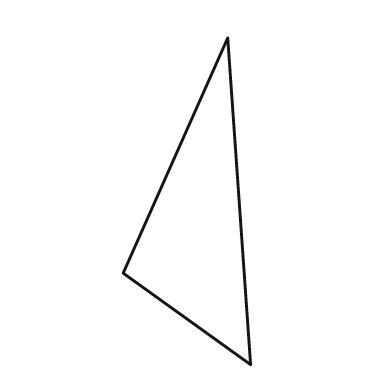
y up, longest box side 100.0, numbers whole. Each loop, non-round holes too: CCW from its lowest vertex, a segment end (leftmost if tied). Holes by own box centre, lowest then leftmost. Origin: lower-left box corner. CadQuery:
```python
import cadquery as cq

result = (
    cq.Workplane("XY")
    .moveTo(39.0, 0.0)
    .lineTo(32.0, 100.0)
    .lineTo(0.0, 28.0)
    .close()
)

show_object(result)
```